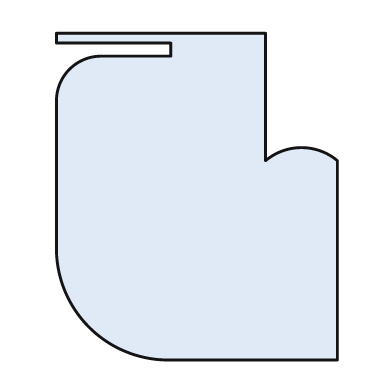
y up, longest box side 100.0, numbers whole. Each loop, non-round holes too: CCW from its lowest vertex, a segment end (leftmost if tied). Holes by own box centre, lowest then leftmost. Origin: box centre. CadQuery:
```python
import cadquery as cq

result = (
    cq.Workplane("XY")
    .moveTo(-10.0, -50.0)
    .lineTo(43.0, -50.0)
    .lineTo(43.0, 11.0)
    .threePointArc((32.0, 15.0), (21.0, 11.0))
    .lineTo(21.0, 50.0)
    .lineTo(-43.0, 50.0)
    .lineTo(-43.0, 47.0)
    .lineTo(-8.0, 47.0)
    .lineTo(-8.0, 43.0)
    .lineTo(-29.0, 43.0)
    .threePointArc((-39.0, 39.0), (-43.0, 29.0))
    .lineTo(-43.0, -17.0)
    .threePointArc((-33.0, -40.0), (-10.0, -50.0))
    .close()
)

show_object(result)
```